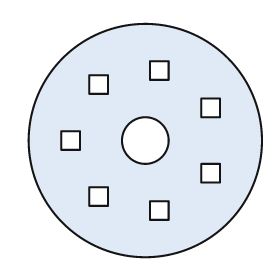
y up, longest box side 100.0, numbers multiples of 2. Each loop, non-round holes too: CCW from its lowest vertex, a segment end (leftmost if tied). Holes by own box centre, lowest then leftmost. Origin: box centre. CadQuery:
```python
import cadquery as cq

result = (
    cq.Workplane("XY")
    .moveTo(0.0, 0.0)
    .circle(50.0)
    .moveTo(2.0, -34.0)
    .lineTo(10.0, -34.0)
    .lineTo(10.0, -26.0)
    .lineTo(2.0, -26.0)
    .close()
    .moveTo(-24.0, -28.0)
    .lineTo(-16.0, -28.0)
    .lineTo(-16.0, -20.0)
    .lineTo(-24.0, -20.0)
    .close()
    .moveTo(24.0, -18.0)
    .lineTo(32.0, -18.0)
    .lineTo(32.0, -10.0)
    .lineTo(24.0, -10.0)
    .close()
    .moveTo(-36.0, -4.0)
    .lineTo(-28.0, -4.0)
    .lineTo(-28.0, 4.0)
    .lineTo(-36.0, 4.0)
    .close()
    .moveTo(0.0, 0.0)
    .circle(10.0)
    .moveTo(24.0, 10.0)
    .lineTo(32.0, 10.0)
    .lineTo(32.0, 18.0)
    .lineTo(24.0, 18.0)
    .close()
    .moveTo(-24.0, 20.0)
    .lineTo(-16.0, 20.0)
    .lineTo(-16.0, 28.0)
    .lineTo(-24.0, 28.0)
    .close()
    .moveTo(2.0, 26.0)
    .lineTo(10.0, 26.0)
    .lineTo(10.0, 34.0)
    .lineTo(2.0, 34.0)
    .close()
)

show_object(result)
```